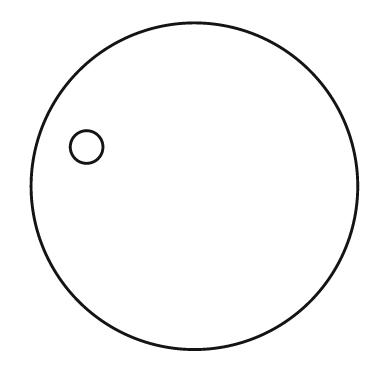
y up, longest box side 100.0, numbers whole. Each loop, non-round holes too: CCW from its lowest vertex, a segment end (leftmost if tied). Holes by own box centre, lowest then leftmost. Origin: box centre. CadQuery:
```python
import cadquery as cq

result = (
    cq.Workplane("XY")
    .moveTo(0.0, 0.0)
    .circle(50.0)
    .moveTo(-33.0, 12.0)
    .circle(5.0)
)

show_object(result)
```